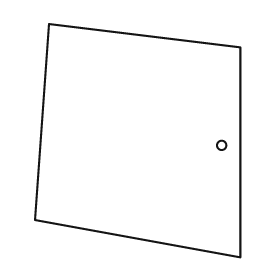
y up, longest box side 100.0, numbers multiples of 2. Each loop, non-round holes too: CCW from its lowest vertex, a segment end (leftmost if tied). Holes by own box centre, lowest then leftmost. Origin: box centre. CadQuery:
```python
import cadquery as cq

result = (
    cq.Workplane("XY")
    .moveTo(44.0, -50.0)
    .lineTo(44.0, 40.0)
    .lineTo(-38.0, 50.0)
    .lineTo(-44.0, -34.0)
    .close()
    .moveTo(36.0, -2.0)
    .circle(2.0)
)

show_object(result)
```